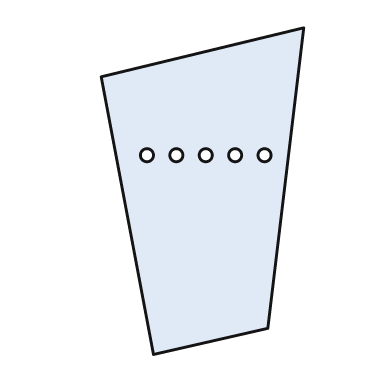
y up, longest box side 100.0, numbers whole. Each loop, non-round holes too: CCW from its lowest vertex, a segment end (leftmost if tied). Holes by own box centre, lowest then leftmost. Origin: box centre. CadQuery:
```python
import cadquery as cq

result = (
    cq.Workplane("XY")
    .moveTo(-15.0, -50.0)
    .lineTo(20.0, -42.0)
    .lineTo(31.0, 50.0)
    .lineTo(-31.0, 35.0)
    .close()
    .moveTo(-17.0, 11.0)
    .circle(2.0)
    .moveTo(-8.0, 11.0)
    .circle(2.0)
    .moveTo(1.0, 11.0)
    .circle(2.0)
    .moveTo(10.0, 11.0)
    .circle(2.0)
    .moveTo(19.0, 11.0)
    .circle(2.0)
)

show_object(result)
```